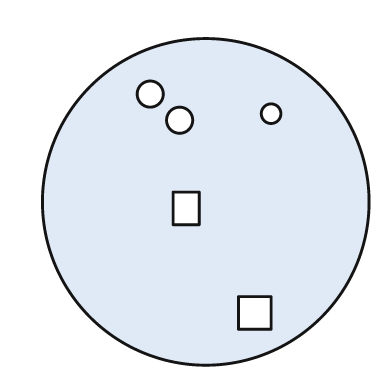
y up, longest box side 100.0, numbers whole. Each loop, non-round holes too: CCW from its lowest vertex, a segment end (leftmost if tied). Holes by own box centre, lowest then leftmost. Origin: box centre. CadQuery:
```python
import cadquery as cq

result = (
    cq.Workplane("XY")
    .moveTo(0.0, 0.0)
    .circle(50.0)
    .moveTo(10.0, -39.0)
    .lineTo(20.0, -39.0)
    .lineTo(20.0, -29.0)
    .lineTo(10.0, -29.0)
    .close()
    .moveTo(-10.0, -7.0)
    .lineTo(-2.0, -7.0)
    .lineTo(-2.0, 3.0)
    .lineTo(-10.0, 3.0)
    .close()
    .moveTo(-8.0, 25.0)
    .circle(4.0)
    .moveTo(20.0, 27.0)
    .circle(3.0)
    .moveTo(-17.0, 33.0)
    .circle(4.0)
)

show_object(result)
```